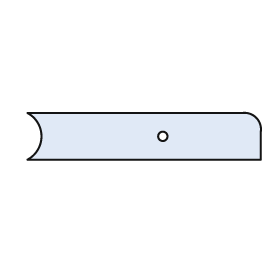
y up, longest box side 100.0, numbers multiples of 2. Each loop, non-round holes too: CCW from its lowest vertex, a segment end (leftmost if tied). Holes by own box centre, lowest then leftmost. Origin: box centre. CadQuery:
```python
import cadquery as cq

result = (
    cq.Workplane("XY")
    .moveTo(-50.0, -10.0)
    .lineTo(50.0, -10.0)
    .lineTo(50.0, 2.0)
    .threePointArc((48.0, 8.0), (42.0, 10.0))
    .lineTo(-50.0, 10.0)
    .threePointArc((-44.0, 0.0), (-50.0, -10.0))
    .close()
    .moveTo(8.0, 0.0)
    .circle(2.0)
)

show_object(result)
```